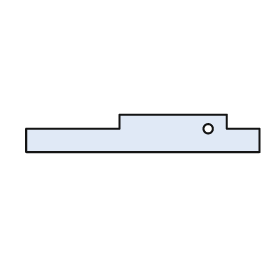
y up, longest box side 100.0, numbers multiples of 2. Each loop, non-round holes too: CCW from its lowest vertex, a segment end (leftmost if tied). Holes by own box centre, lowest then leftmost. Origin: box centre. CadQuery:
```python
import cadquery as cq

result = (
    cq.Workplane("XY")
    .moveTo(-50.0, -8.0)
    .lineTo(50.0, -8.0)
    .lineTo(50.0, 2.0)
    .lineTo(36.0, 2.0)
    .lineTo(36.0, 8.0)
    .lineTo(-10.0, 8.0)
    .lineTo(-10.0, 2.0)
    .lineTo(-50.0, 2.0)
    .close()
    .moveTo(28.0, 2.0)
    .circle(2.0)
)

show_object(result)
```